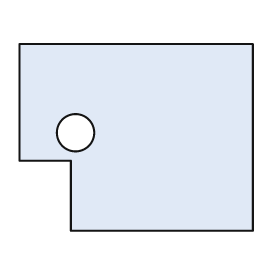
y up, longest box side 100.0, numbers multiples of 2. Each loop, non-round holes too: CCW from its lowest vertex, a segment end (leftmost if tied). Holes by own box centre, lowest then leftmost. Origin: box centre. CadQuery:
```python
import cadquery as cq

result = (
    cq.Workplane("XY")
    .moveTo(-28.0, -40.0)
    .lineTo(50.0, -40.0)
    .lineTo(50.0, 40.0)
    .lineTo(-50.0, 40.0)
    .lineTo(-50.0, -10.0)
    .lineTo(-28.0, -10.0)
    .close()
    .moveTo(-26.0, 2.0)
    .circle(8.0)
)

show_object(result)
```